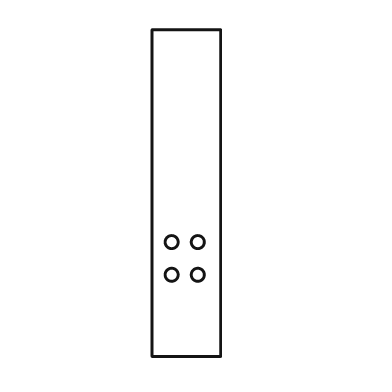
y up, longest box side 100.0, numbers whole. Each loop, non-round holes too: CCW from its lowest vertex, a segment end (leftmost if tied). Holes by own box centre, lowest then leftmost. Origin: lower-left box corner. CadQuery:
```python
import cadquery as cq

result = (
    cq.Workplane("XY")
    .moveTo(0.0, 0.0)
    .lineTo(21.0, 0.0)
    .lineTo(21.0, 100.0)
    .lineTo(0.0, 100.0)
    .close()
    .moveTo(6.0, 25.0)
    .circle(2.0)
    .moveTo(14.0, 25.0)
    .circle(2.0)
    .moveTo(6.0, 35.0)
    .circle(2.0)
    .moveTo(14.0, 35.0)
    .circle(2.0)
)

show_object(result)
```